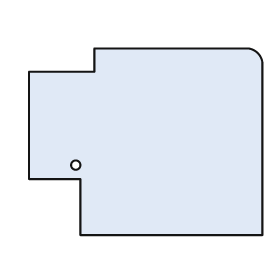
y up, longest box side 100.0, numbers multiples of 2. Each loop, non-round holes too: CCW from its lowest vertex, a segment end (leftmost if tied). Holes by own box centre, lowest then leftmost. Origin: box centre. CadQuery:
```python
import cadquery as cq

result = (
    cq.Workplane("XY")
    .moveTo(-28.0, -40.0)
    .lineTo(50.0, -40.0)
    .lineTo(50.0, 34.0)
    .threePointArc((48.0, 38.0), (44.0, 40.0))
    .lineTo(-22.0, 40.0)
    .lineTo(-22.0, 30.0)
    .lineTo(-50.0, 30.0)
    .lineTo(-50.0, -16.0)
    .lineTo(-28.0, -16.0)
    .close()
    .moveTo(-30.0, -10.0)
    .circle(2.0)
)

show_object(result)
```